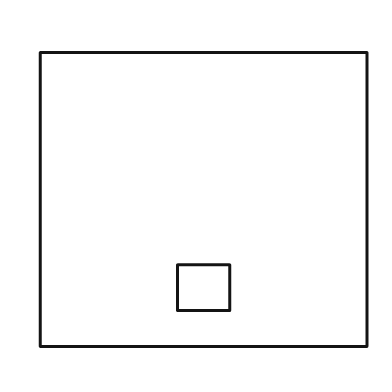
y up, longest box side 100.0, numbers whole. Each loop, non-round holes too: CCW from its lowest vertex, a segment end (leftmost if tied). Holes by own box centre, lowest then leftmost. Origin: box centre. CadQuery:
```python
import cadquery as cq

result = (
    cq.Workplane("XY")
    .moveTo(-50.0, -45.0)
    .lineTo(50.0, -45.0)
    .lineTo(50.0, 45.0)
    .lineTo(-50.0, 45.0)
    .close()
    .moveTo(-8.0, -34.0)
    .lineTo(8.0, -34.0)
    .lineTo(8.0, -20.0)
    .lineTo(-8.0, -20.0)
    .close()
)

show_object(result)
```